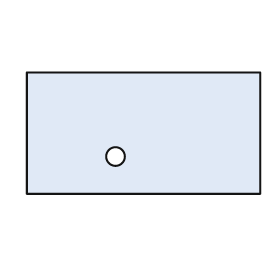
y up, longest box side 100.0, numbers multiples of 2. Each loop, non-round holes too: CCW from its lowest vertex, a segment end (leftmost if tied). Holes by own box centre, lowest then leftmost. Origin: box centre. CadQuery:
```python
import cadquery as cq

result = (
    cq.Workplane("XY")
    .moveTo(-50.0, -26.0)
    .lineTo(50.0, -26.0)
    .lineTo(50.0, 26.0)
    .lineTo(-50.0, 26.0)
    .close()
    .moveTo(-12.0, -10.0)
    .circle(4.0)
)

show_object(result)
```